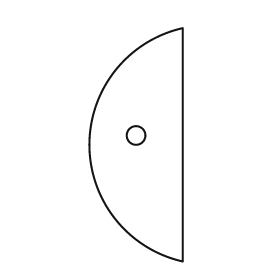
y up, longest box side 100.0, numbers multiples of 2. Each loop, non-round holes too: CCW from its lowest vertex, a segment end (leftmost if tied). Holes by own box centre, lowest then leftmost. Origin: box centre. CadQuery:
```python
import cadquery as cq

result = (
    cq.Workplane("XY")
    .moveTo(20.0, -50.0)
    .lineTo(20.0, 50.0)
    .threePointArc((-20.0, 0.0), (20.0, -50.0))
    .close()
    .moveTo(0.0, 4.0)
    .circle(4.0)
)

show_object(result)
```